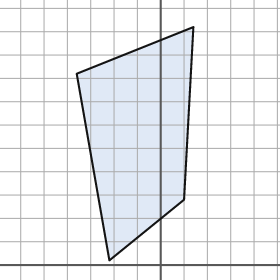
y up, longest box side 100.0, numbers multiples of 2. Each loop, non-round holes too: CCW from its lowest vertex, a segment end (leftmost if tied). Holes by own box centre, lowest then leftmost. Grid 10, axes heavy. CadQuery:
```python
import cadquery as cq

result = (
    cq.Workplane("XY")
    .moveTo(-22.0, 2.0)
    .lineTo(10.0, 28.0)
    .lineTo(14.0, 102.0)
    .lineTo(-36.0, 82.0)
    .close()
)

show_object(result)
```